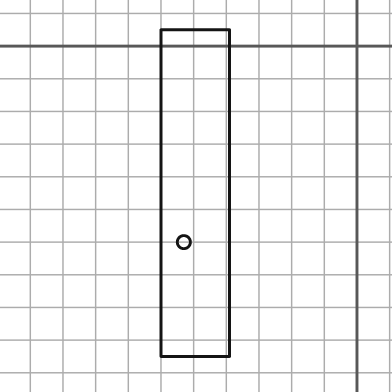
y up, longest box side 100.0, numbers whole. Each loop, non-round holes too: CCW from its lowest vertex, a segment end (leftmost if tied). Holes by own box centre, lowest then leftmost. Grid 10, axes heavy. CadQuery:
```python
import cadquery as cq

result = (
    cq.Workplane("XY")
    .moveTo(-60.0, -95.0)
    .lineTo(-39.0, -95.0)
    .lineTo(-39.0, 5.0)
    .lineTo(-60.0, 5.0)
    .close()
    .moveTo(-53.0, -60.0)
    .circle(2.0)
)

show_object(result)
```